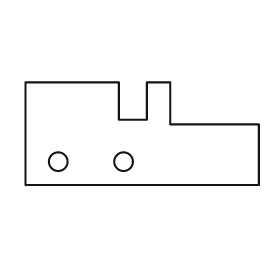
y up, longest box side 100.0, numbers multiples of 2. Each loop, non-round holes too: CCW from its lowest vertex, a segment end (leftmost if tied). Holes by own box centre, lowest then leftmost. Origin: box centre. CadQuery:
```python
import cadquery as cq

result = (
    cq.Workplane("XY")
    .moveTo(-50.0, -22.0)
    .lineTo(50.0, -22.0)
    .lineTo(50.0, 4.0)
    .lineTo(12.0, 4.0)
    .lineTo(12.0, 22.0)
    .lineTo(2.0, 22.0)
    .lineTo(2.0, 6.0)
    .lineTo(-10.0, 6.0)
    .lineTo(-10.0, 22.0)
    .lineTo(-50.0, 22.0)
    .close()
    .moveTo(-36.0, -12.0)
    .circle(4.0)
    .moveTo(-8.0, -12.0)
    .circle(4.0)
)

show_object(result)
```